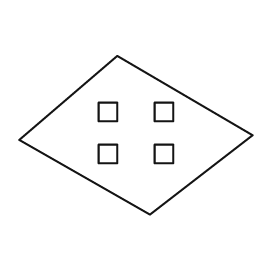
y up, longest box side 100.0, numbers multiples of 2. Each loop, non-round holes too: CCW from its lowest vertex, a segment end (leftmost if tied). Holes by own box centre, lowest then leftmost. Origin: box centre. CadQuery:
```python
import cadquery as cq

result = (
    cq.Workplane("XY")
    .moveTo(6.0, -34.0)
    .lineTo(50.0, 0.0)
    .lineTo(-8.0, 34.0)
    .lineTo(-50.0, -2.0)
    .close()
    .moveTo(-16.0, -12.0)
    .lineTo(-8.0, -12.0)
    .lineTo(-8.0, -4.0)
    .lineTo(-16.0, -4.0)
    .close()
    .moveTo(8.0, -12.0)
    .lineTo(16.0, -12.0)
    .lineTo(16.0, -4.0)
    .lineTo(8.0, -4.0)
    .close()
    .moveTo(-16.0, 6.0)
    .lineTo(-8.0, 6.0)
    .lineTo(-8.0, 14.0)
    .lineTo(-16.0, 14.0)
    .close()
    .moveTo(8.0, 6.0)
    .lineTo(16.0, 6.0)
    .lineTo(16.0, 14.0)
    .lineTo(8.0, 14.0)
    .close()
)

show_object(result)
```